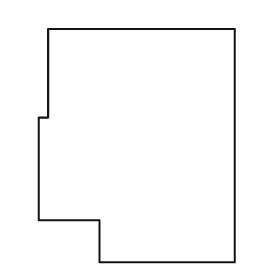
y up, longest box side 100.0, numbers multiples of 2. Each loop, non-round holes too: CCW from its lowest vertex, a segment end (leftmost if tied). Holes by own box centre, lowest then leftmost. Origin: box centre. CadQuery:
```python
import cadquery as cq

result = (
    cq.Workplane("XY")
    .moveTo(-16.0, -50.0)
    .lineTo(42.0, -50.0)
    .lineTo(42.0, 50.0)
    .lineTo(-38.0, 50.0)
    .lineTo(-38.0, 12.0)
    .lineTo(-42.0, 12.0)
    .lineTo(-42.0, -32.0)
    .lineTo(-16.0, -32.0)
    .close()
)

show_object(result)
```